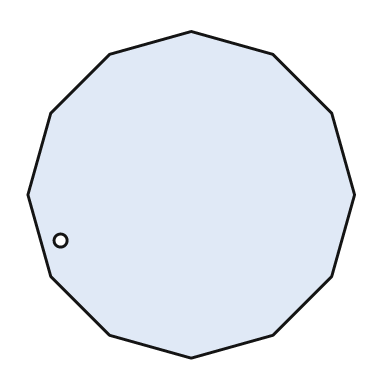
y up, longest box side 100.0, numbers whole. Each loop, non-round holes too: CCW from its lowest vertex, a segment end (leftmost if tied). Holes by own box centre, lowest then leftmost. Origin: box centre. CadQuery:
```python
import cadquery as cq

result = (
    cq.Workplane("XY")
    .moveTo(0.0, -50.0)
    .lineTo(25.0, -43.0)
    .lineTo(43.0, -25.0)
    .lineTo(50.0, 0.0)
    .lineTo(43.0, 25.0)
    .lineTo(25.0, 43.0)
    .lineTo(0.0, 50.0)
    .lineTo(-25.0, 43.0)
    .lineTo(-43.0, 25.0)
    .lineTo(-50.0, 0.0)
    .lineTo(-43.0, -25.0)
    .lineTo(-25.0, -43.0)
    .close()
    .moveTo(-40.0, -14.0)
    .circle(2.0)
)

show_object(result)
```